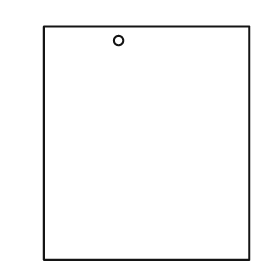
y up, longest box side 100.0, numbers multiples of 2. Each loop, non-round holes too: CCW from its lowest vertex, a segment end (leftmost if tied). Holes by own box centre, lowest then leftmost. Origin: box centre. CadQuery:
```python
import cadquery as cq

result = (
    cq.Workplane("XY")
    .moveTo(-44.0, -50.0)
    .lineTo(44.0, -50.0)
    .lineTo(44.0, 50.0)
    .lineTo(-44.0, 50.0)
    .close()
    .moveTo(-12.0, 44.0)
    .circle(2.0)
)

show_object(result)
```